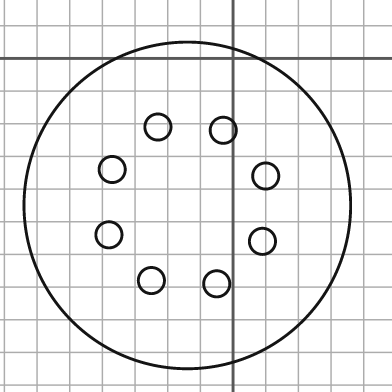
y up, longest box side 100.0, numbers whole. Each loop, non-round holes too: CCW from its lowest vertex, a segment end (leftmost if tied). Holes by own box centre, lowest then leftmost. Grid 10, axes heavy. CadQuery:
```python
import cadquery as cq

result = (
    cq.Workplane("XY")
    .moveTo(-14.0, -45.0)
    .circle(50.0)
    .moveTo(-5.0, -69.0)
    .circle(4.0)
    .moveTo(-25.0, -68.0)
    .circle(4.0)
    .moveTo(9.0, -56.0)
    .circle(4.0)
    .moveTo(-38.0, -54.0)
    .circle(4.0)
    .moveTo(10.0, -36.0)
    .circle(4.0)
    .moveTo(-37.0, -34.0)
    .circle(4.0)
    .moveTo(-3.0, -22.0)
    .circle(4.0)
    .moveTo(-23.0, -21.0)
    .circle(4.0)
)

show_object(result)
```